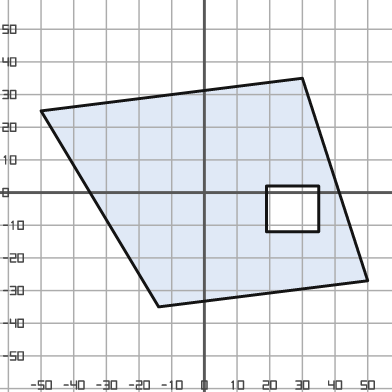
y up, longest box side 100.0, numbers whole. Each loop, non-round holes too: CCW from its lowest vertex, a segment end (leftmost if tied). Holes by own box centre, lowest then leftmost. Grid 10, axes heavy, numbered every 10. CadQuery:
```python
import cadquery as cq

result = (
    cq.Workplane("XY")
    .moveTo(-14.0, -35.0)
    .lineTo(50.0, -27.0)
    .lineTo(30.0, 35.0)
    .lineTo(-50.0, 25.0)
    .close()
    .moveTo(19.0, -12.0)
    .lineTo(35.0, -12.0)
    .lineTo(35.0, 2.0)
    .lineTo(19.0, 2.0)
    .close()
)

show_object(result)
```